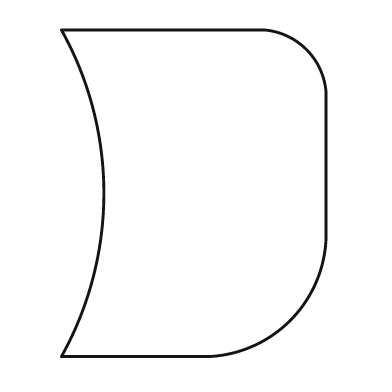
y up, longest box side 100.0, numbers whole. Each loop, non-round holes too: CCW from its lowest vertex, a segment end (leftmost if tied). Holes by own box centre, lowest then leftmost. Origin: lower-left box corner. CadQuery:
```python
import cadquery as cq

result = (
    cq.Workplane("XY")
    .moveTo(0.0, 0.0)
    .lineTo(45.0, 0.0)
    .threePointArc((70.0, 11.0), (81.0, 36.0))
    .lineTo(81.0, 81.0)
    .threePointArc((75.0, 94.0), (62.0, 100.0))
    .lineTo(0.0, 100.0)
    .threePointArc((13.0, 50.0), (0.0, 0.0))
    .close()
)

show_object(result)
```